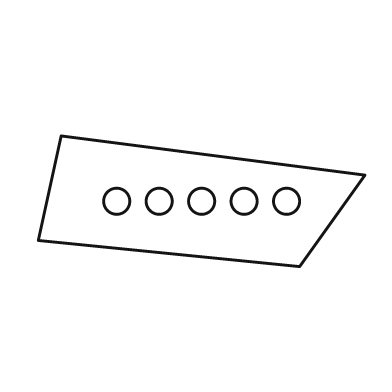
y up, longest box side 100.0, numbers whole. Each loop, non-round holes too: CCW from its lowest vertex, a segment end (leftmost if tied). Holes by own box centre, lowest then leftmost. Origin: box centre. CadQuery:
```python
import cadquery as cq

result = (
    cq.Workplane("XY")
    .moveTo(30.0, -20.0)
    .lineTo(50.0, 8.0)
    .lineTo(-43.0, 20.0)
    .lineTo(-50.0, -12.0)
    .close()
    .moveTo(-26.0, 0.0)
    .circle(4.0)
    .moveTo(-13.0, 0.0)
    .circle(4.0)
    .moveTo(0.0, 0.0)
    .circle(4.0)
    .moveTo(13.0, 0.0)
    .circle(4.0)
    .moveTo(26.0, 0.0)
    .circle(4.0)
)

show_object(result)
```